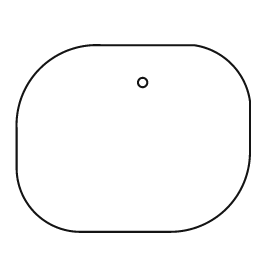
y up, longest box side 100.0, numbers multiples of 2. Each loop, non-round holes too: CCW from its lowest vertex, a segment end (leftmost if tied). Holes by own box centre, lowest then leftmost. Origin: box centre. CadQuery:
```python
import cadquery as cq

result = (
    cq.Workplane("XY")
    .moveTo(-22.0, -40.0)
    .lineTo(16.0, -40.0)
    .threePointArc((40.0, -30.0), (50.0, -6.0))
    .lineTo(50.0, 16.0)
    .threePointArc((42.0, 32.0), (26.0, 40.0))
    .lineTo(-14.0, 40.0)
    .threePointArc((-40.0, 30.0), (-50.0, 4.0))
    .lineTo(-50.0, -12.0)
    .threePointArc((-42.0, -32.0), (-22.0, -40.0))
    .close()
    .moveTo(4.0, 24.0)
    .circle(2.0)
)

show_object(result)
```